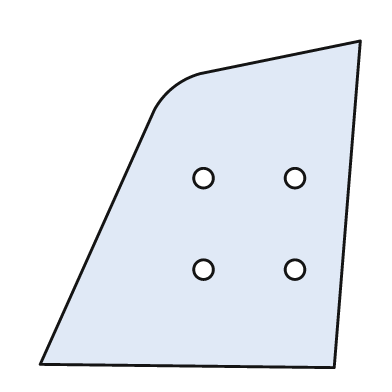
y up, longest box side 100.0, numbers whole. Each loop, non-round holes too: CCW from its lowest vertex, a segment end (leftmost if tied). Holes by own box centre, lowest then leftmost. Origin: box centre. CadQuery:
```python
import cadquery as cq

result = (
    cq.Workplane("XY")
    .moveTo(41.0, -50.0)
    .lineTo(49.0, 50.0)
    .lineTo(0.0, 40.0)
    .threePointArc((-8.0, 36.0), (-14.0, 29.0))
    .lineTo(-49.0, -49.0)
    .close()
    .moveTo(1.0, -20.0)
    .circle(3.0)
    .moveTo(29.0, -20.0)
    .circle(3.0)
    .moveTo(1.0, 8.0)
    .circle(3.0)
    .moveTo(29.0, 8.0)
    .circle(3.0)
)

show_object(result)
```